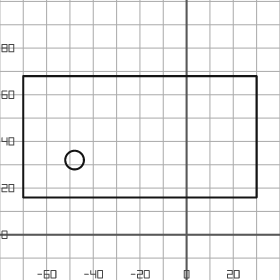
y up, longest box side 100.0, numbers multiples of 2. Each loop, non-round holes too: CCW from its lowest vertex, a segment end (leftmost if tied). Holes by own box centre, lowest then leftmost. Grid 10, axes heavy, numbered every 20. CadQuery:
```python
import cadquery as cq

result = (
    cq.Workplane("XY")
    .moveTo(-70.0, 16.0)
    .lineTo(30.0, 16.0)
    .lineTo(30.0, 68.0)
    .lineTo(-70.0, 68.0)
    .close()
    .moveTo(-48.0, 32.0)
    .circle(4.0)
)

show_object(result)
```